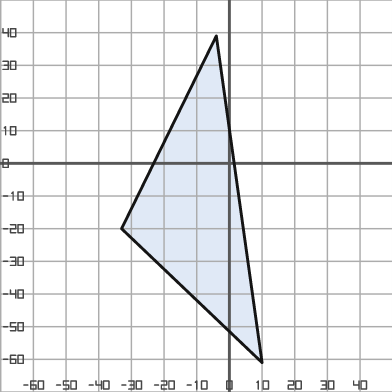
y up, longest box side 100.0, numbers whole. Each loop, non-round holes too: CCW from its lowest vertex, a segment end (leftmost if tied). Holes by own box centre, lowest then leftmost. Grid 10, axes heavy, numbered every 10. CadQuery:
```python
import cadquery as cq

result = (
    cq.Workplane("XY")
    .moveTo(10.0, -61.0)
    .lineTo(-4.0, 39.0)
    .lineTo(-33.0, -20.0)
    .close()
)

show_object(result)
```